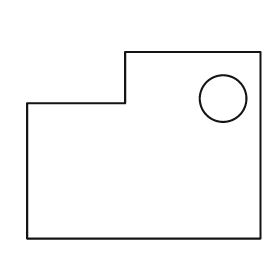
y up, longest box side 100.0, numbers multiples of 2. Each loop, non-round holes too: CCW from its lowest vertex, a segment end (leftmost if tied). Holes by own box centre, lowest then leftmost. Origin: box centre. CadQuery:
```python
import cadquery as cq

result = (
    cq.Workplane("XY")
    .moveTo(-50.0, -40.0)
    .lineTo(50.0, -40.0)
    .lineTo(50.0, 40.0)
    .lineTo(-8.0, 40.0)
    .lineTo(-8.0, 18.0)
    .lineTo(-50.0, 18.0)
    .close()
    .moveTo(34.0, 20.0)
    .circle(10.0)
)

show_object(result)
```